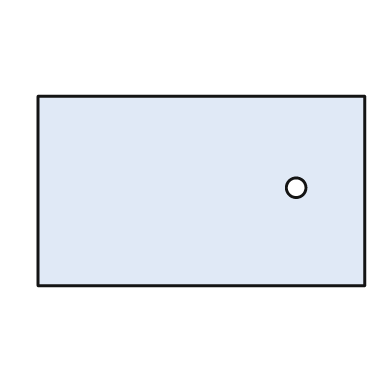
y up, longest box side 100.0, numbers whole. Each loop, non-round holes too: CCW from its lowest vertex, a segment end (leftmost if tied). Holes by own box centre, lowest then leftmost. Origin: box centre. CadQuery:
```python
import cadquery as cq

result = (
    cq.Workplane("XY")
    .moveTo(-50.0, -29.0)
    .lineTo(50.0, -29.0)
    .lineTo(50.0, 29.0)
    .lineTo(-50.0, 29.0)
    .close()
    .moveTo(29.0, 1.0)
    .circle(3.0)
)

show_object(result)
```